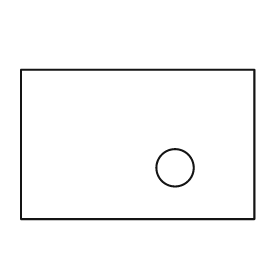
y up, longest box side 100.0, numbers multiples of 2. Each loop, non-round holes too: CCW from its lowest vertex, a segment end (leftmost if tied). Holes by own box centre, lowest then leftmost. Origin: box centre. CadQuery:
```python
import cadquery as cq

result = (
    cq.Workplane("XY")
    .moveTo(-50.0, -32.0)
    .lineTo(50.0, -32.0)
    .lineTo(50.0, 32.0)
    .lineTo(-50.0, 32.0)
    .close()
    .moveTo(16.0, -10.0)
    .circle(8.0)
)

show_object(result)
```